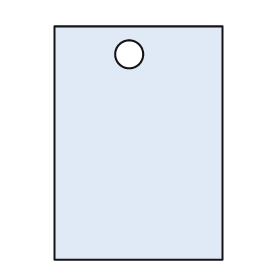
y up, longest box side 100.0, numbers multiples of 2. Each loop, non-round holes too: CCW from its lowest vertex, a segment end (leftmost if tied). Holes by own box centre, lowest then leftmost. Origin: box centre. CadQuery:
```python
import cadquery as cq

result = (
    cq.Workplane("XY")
    .moveTo(-36.0, -50.0)
    .lineTo(36.0, -50.0)
    .lineTo(36.0, 50.0)
    .lineTo(-36.0, 50.0)
    .close()
    .moveTo(-4.0, 38.0)
    .circle(6.0)
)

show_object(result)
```